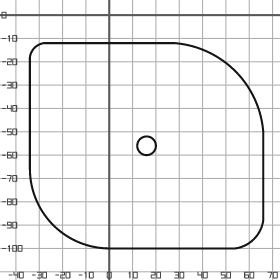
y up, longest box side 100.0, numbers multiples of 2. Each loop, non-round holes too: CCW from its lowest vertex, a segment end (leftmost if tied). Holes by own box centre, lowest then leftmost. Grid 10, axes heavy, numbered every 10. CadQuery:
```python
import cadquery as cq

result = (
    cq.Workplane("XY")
    .moveTo(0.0, -100.0)
    .lineTo(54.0, -100.0)
    .threePointArc((62.0, -96.0), (66.0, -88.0))
    .lineTo(66.0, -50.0)
    .threePointArc((54.0, -24.0), (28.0, -12.0))
    .lineTo(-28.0, -12.0)
    .threePointArc((-32.0, -14.0), (-34.0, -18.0))
    .lineTo(-34.0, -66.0)
    .threePointArc((-24.0, -90.0), (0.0, -100.0))
    .close()
    .moveTo(16.0, -56.0)
    .circle(4.0)
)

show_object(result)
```